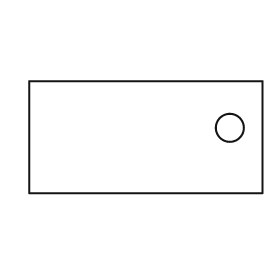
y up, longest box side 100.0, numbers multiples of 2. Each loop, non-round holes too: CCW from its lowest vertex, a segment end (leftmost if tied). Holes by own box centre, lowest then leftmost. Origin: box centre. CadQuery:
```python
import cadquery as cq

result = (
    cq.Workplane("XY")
    .moveTo(-50.0, -24.0)
    .lineTo(50.0, -24.0)
    .lineTo(50.0, 24.0)
    .lineTo(-50.0, 24.0)
    .close()
    .moveTo(36.0, 4.0)
    .circle(6.0)
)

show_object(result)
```